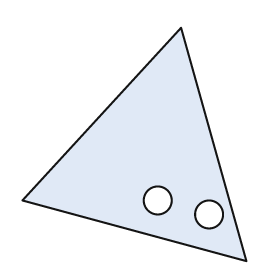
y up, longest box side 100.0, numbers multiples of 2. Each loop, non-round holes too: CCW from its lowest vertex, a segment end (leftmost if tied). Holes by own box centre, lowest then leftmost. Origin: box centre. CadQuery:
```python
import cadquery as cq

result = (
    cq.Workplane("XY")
    .moveTo(48.0, -50.0)
    .lineTo(20.0, 50.0)
    .lineTo(-48.0, -24.0)
    .close()
    .moveTo(32.0, -30.0)
    .circle(6.0)
    .moveTo(10.0, -24.0)
    .circle(6.0)
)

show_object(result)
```